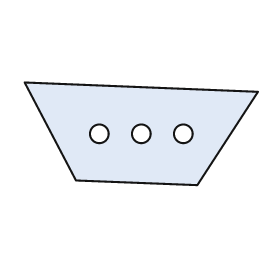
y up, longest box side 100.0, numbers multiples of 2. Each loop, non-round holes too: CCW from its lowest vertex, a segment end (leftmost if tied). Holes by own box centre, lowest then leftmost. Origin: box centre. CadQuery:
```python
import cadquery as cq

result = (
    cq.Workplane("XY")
    .moveTo(24.0, -22.0)
    .lineTo(50.0, 18.0)
    .lineTo(-50.0, 22.0)
    .lineTo(-28.0, -20.0)
    .close()
    .moveTo(-18.0, 0.0)
    .circle(4.0)
    .moveTo(0.0, 0.0)
    .circle(4.0)
    .moveTo(18.0, 0.0)
    .circle(4.0)
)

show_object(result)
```